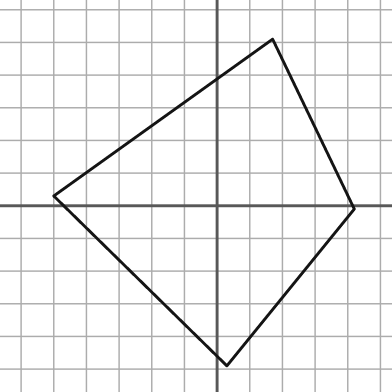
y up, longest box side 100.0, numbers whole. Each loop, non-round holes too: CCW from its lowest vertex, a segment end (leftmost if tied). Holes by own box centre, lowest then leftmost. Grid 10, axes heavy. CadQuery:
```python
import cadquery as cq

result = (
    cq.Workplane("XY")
    .moveTo(3.0, -49.0)
    .lineTo(42.0, -1.0)
    .lineTo(17.0, 51.0)
    .lineTo(-50.0, 3.0)
    .close()
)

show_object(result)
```